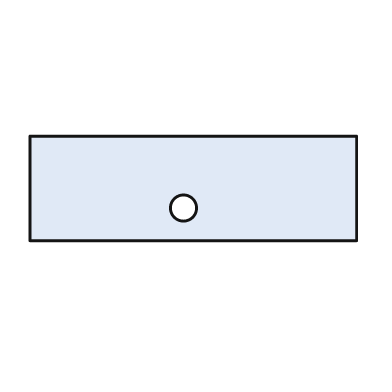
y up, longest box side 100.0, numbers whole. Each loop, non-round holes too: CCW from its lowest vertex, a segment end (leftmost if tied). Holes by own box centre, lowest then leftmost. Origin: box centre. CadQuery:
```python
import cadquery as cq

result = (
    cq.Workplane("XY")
    .moveTo(-50.0, -16.0)
    .lineTo(50.0, -16.0)
    .lineTo(50.0, 16.0)
    .lineTo(-50.0, 16.0)
    .close()
    .moveTo(-3.0, -6.0)
    .circle(4.0)
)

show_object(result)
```